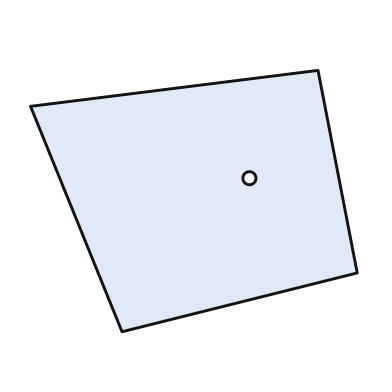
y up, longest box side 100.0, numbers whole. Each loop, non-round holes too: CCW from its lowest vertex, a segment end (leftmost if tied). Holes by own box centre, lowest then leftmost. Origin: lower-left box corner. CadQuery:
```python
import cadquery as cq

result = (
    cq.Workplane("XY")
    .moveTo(28.0, 0.0)
    .lineTo(100.0, 18.0)
    .lineTo(88.0, 80.0)
    .lineTo(0.0, 69.0)
    .close()
    .moveTo(67.0, 47.0)
    .circle(2.0)
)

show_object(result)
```